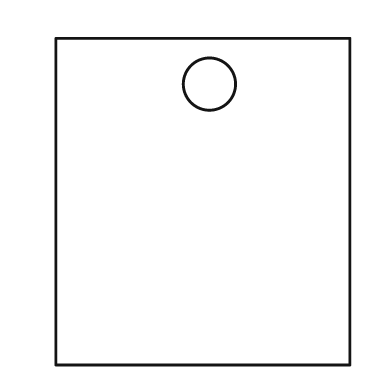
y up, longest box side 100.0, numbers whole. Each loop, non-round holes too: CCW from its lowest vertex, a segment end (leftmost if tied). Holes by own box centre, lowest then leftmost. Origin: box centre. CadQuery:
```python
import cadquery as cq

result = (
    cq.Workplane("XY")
    .moveTo(-45.0, -50.0)
    .lineTo(45.0, -50.0)
    .lineTo(45.0, 50.0)
    .lineTo(-45.0, 50.0)
    .close()
    .moveTo(2.0, 36.0)
    .circle(8.0)
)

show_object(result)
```